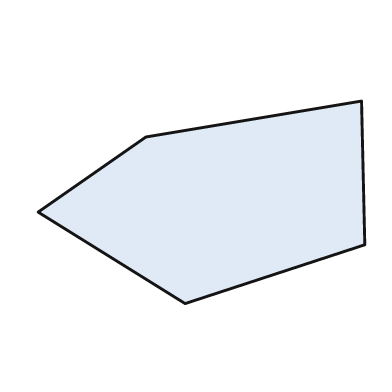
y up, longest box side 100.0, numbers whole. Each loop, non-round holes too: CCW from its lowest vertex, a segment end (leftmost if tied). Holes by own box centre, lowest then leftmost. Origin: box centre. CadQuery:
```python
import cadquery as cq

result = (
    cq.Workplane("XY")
    .moveTo(-5.0, -31.0)
    .lineTo(50.0, -13.0)
    .lineTo(49.0, 31.0)
    .lineTo(-17.0, 20.0)
    .lineTo(-50.0, -3.0)
    .close()
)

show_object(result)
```